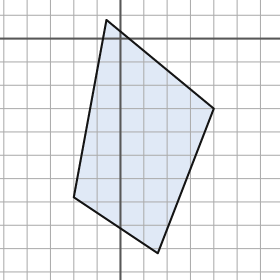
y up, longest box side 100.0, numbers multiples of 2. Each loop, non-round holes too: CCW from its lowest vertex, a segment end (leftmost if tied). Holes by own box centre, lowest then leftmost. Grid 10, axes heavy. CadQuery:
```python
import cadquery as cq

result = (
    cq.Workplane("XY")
    .moveTo(16.0, -92.0)
    .lineTo(40.0, -30.0)
    .lineTo(-6.0, 8.0)
    .lineTo(-20.0, -68.0)
    .close()
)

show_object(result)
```